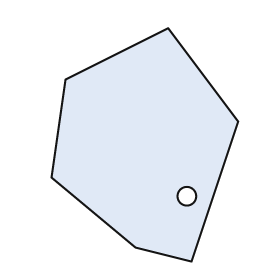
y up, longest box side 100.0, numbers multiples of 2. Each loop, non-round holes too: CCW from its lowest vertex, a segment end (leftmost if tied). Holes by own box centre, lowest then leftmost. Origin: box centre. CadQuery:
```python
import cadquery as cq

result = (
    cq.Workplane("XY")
    .moveTo(20.0, -50.0)
    .lineTo(40.0, 10.0)
    .lineTo(10.0, 50.0)
    .lineTo(-34.0, 28.0)
    .lineTo(-40.0, -14.0)
    .lineTo(-4.0, -44.0)
    .close()
    .moveTo(18.0, -22.0)
    .circle(4.0)
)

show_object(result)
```